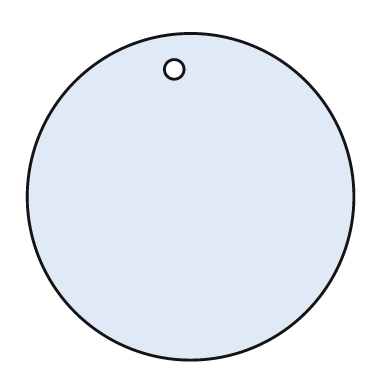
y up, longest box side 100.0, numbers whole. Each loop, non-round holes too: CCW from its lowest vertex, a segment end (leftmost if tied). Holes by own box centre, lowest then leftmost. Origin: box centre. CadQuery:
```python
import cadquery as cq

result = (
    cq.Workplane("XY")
    .moveTo(0.0, 0.0)
    .circle(50.0)
    .moveTo(-5.0, 39.0)
    .circle(3.0)
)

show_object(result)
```